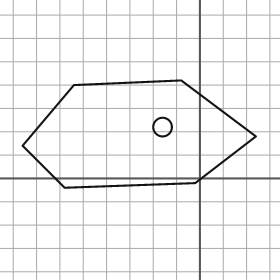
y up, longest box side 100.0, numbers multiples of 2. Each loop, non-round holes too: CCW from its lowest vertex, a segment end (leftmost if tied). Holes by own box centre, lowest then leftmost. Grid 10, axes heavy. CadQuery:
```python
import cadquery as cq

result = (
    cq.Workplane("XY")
    .moveTo(-58.0, -4.0)
    .lineTo(-2.0, -2.0)
    .lineTo(24.0, 18.0)
    .lineTo(-8.0, 42.0)
    .lineTo(-54.0, 40.0)
    .lineTo(-76.0, 14.0)
    .close()
    .moveTo(-16.0, 22.0)
    .circle(4.0)
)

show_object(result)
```